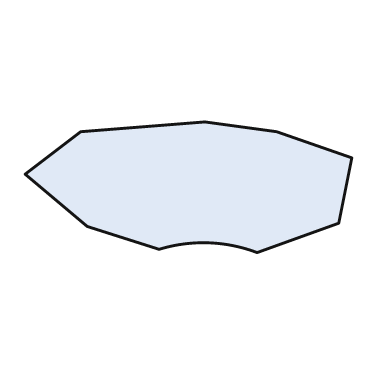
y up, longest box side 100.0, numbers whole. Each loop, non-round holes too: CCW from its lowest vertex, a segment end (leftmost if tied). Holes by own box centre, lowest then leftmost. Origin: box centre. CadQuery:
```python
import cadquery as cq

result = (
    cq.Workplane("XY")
    .moveTo(21.0, -20.0)
    .lineTo(46.0, -11.0)
    .lineTo(50.0, 9.0)
    .lineTo(27.0, 17.0)
    .lineTo(5.0, 20.0)
    .lineTo(-33.0, 17.0)
    .lineTo(-50.0, 4.0)
    .lineTo(-31.0, -12.0)
    .lineTo(-9.0, -19.0)
    .threePointArc((6.0, -17.0), (21.0, -20.0))
    .close()
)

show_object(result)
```